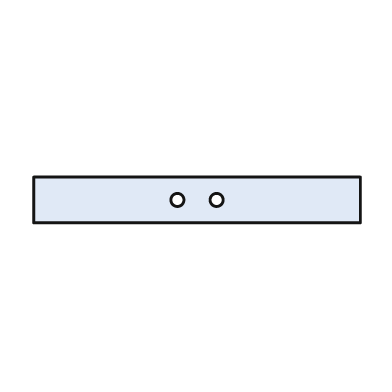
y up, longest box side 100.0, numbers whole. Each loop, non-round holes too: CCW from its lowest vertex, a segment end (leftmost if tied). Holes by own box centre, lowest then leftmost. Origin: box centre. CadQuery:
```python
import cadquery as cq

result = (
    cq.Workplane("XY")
    .moveTo(-50.0, -7.0)
    .lineTo(50.0, -7.0)
    .lineTo(50.0, 7.0)
    .lineTo(-50.0, 7.0)
    .close()
    .moveTo(-6.0, 0.0)
    .circle(2.0)
    .moveTo(6.0, 0.0)
    .circle(2.0)
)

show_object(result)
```